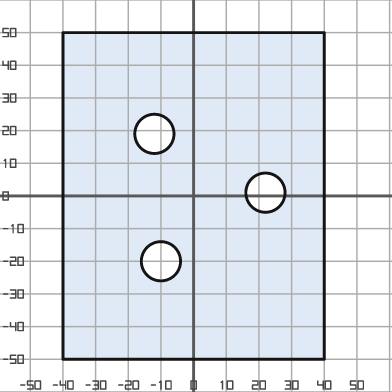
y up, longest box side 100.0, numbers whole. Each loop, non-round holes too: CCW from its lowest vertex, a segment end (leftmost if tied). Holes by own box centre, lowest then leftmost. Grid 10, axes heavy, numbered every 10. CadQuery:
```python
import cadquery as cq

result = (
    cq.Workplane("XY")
    .moveTo(-40.0, -50.0)
    .lineTo(40.0, -50.0)
    .lineTo(40.0, 50.0)
    .lineTo(-40.0, 50.0)
    .close()
    .moveTo(-10.0, -20.0)
    .circle(6.0)
    .moveTo(22.0, 1.0)
    .circle(6.0)
    .moveTo(-12.0, 19.0)
    .circle(6.0)
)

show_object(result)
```